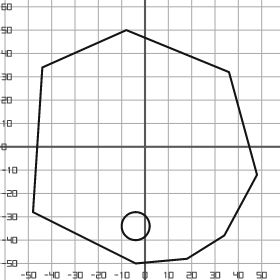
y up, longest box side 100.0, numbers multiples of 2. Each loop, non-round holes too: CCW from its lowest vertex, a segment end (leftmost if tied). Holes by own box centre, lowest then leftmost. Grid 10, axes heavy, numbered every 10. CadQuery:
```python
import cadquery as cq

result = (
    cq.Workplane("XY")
    .moveTo(-4.0, -50.0)
    .lineTo(18.0, -48.0)
    .lineTo(34.0, -38.0)
    .lineTo(48.0, -12.0)
    .lineTo(36.0, 32.0)
    .lineTo(-8.0, 50.0)
    .lineTo(-44.0, 34.0)
    .lineTo(-48.0, -28.0)
    .close()
    .moveTo(-4.0, -34.0)
    .circle(6.0)
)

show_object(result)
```